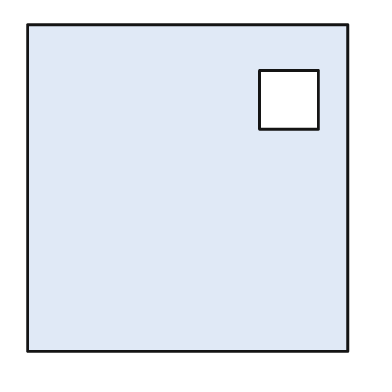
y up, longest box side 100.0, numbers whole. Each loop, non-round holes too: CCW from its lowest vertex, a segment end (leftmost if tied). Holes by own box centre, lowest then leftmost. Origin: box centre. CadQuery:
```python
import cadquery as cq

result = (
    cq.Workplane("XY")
    .moveTo(-49.0, -50.0)
    .lineTo(49.0, -50.0)
    .lineTo(49.0, 50.0)
    .lineTo(-49.0, 50.0)
    .close()
    .moveTo(22.0, 18.0)
    .lineTo(40.0, 18.0)
    .lineTo(40.0, 36.0)
    .lineTo(22.0, 36.0)
    .close()
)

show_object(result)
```